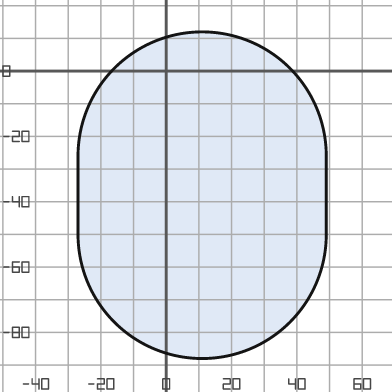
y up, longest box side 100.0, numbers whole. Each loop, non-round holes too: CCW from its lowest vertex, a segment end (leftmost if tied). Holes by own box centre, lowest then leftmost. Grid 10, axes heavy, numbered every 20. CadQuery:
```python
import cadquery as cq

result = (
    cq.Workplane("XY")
    .moveTo(-27.0, -50.0)
    .threePointArc((11.0, -88.0), (49.0, -50.0))
    .lineTo(49.0, -26.0)
    .threePointArc((11.0, 12.0), (-27.0, -26.0))
    .close()
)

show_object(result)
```